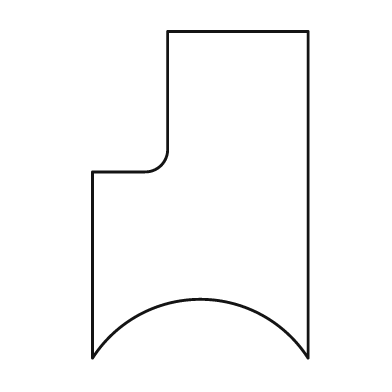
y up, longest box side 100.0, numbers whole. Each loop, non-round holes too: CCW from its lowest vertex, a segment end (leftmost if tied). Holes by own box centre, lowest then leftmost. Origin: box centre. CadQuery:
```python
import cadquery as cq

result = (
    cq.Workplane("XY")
    .moveTo(-33.0, -50.0)
    .threePointArc((0.0, -32.0), (33.0, -50.0))
    .lineTo(33.0, 50.0)
    .lineTo(-10.0, 50.0)
    .lineTo(-10.0, 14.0)
    .threePointArc((-12.0, 9.0), (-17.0, 7.0))
    .lineTo(-33.0, 7.0)
    .close()
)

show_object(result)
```